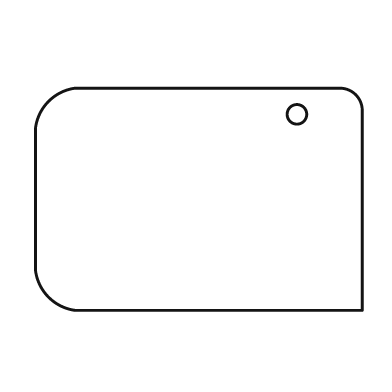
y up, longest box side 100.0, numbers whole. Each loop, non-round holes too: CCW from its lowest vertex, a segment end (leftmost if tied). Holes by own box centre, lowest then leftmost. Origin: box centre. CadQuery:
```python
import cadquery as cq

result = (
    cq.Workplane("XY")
    .moveTo(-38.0, -34.0)
    .lineTo(50.0, -34.0)
    .lineTo(50.0, 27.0)
    .threePointArc((48.0, 32.0), (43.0, 34.0))
    .lineTo(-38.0, 34.0)
    .threePointArc((-46.0, 30.0), (-50.0, 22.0))
    .lineTo(-50.0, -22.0)
    .threePointArc((-46.0, -30.0), (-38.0, -34.0))
    .close()
    .moveTo(30.0, 26.0)
    .circle(3.0)
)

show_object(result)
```